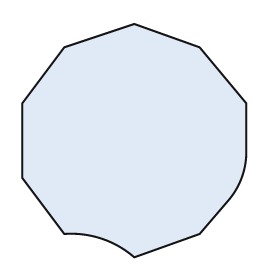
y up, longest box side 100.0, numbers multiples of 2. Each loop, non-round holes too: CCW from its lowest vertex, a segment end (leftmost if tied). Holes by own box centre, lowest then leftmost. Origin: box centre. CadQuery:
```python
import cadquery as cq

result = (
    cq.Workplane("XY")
    .moveTo(0.0, -50.0)
    .lineTo(28.0, -40.0)
    .lineTo(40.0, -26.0)
    .threePointArc((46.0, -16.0), (48.0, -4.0))
    .lineTo(48.0, 16.0)
    .lineTo(28.0, 40.0)
    .lineTo(0.0, 50.0)
    .lineTo(-30.0, 40.0)
    .lineTo(-48.0, 16.0)
    .lineTo(-48.0, -16.0)
    .lineTo(-30.0, -40.0)
    .threePointArc((-14.0, -42.0), (0.0, -50.0))
    .close()
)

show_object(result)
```